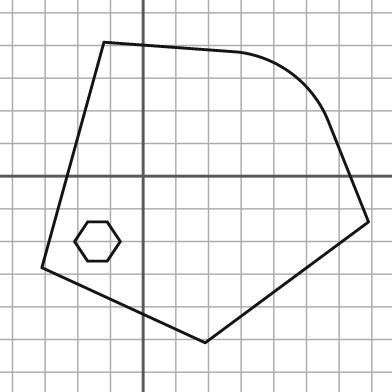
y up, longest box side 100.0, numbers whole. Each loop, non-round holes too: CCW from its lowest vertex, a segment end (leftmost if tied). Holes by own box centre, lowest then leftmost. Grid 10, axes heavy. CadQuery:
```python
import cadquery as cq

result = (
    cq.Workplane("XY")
    .moveTo(19.0, -51.0)
    .lineTo(69.0, -14.0)
    .lineTo(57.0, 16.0)
    .threePointArc((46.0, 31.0), (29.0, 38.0))
    .lineTo(-12.0, 41.0)
    .lineTo(-31.0, -28.0)
    .close()
    .moveTo(-17.0, -26.0)
    .lineTo(-11.0, -26.0)
    .lineTo(-7.0, -20.0)
    .lineTo(-11.0, -14.0)
    .lineTo(-17.0, -14.0)
    .lineTo(-21.0, -20.0)
    .close()
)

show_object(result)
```